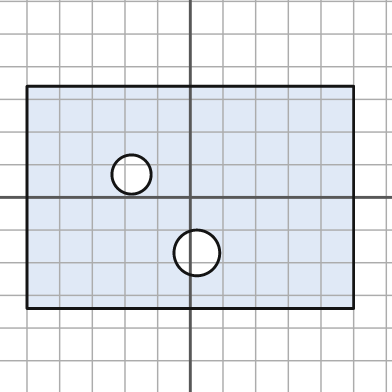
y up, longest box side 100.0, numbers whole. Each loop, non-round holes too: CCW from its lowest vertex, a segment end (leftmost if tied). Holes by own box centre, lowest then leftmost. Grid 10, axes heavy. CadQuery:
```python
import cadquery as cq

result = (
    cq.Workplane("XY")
    .moveTo(-50.0, -34.0)
    .lineTo(50.0, -34.0)
    .lineTo(50.0, 34.0)
    .lineTo(-50.0, 34.0)
    .close()
    .moveTo(2.0, -17.0)
    .circle(7.0)
    .moveTo(-18.0, 7.0)
    .circle(6.0)
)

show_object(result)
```